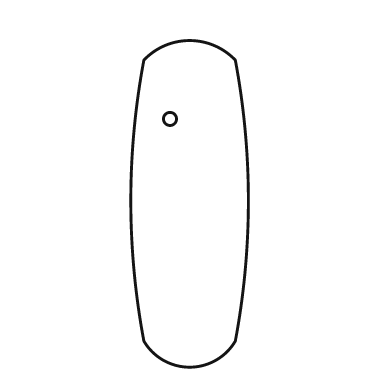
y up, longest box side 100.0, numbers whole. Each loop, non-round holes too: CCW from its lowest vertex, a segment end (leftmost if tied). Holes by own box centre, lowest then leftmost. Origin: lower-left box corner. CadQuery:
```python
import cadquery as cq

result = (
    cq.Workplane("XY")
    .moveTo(4.0, 8.0)
    .threePointArc((18.0, 0.0), (32.0, 8.0))
    .threePointArc((36.0, 51.0), (32.0, 94.0))
    .threePointArc((18.0, 100.0), (4.0, 94.0))
    .threePointArc((0.0, 51.0), (4.0, 8.0))
    .close()
    .moveTo(12.0, 76.0)
    .circle(2.0)
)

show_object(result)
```